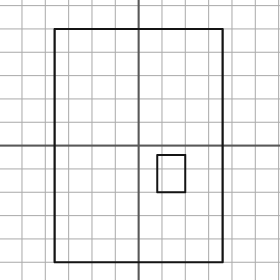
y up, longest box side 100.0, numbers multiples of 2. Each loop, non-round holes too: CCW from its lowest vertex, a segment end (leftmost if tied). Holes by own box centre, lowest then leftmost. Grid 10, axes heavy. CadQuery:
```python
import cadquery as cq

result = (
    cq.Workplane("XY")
    .moveTo(-36.0, -50.0)
    .lineTo(36.0, -50.0)
    .lineTo(36.0, 50.0)
    .lineTo(-36.0, 50.0)
    .close()
    .moveTo(8.0, -20.0)
    .lineTo(20.0, -20.0)
    .lineTo(20.0, -4.0)
    .lineTo(8.0, -4.0)
    .close()
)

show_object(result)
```